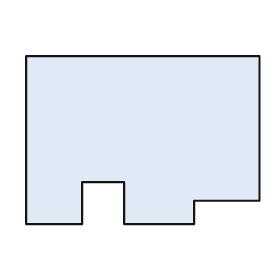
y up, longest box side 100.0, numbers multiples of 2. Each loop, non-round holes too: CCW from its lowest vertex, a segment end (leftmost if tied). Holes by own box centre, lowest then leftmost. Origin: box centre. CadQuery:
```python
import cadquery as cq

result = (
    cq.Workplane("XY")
    .moveTo(-50.0, -36.0)
    .lineTo(-26.0, -36.0)
    .lineTo(-26.0, -18.0)
    .lineTo(-8.0, -18.0)
    .lineTo(-8.0, -36.0)
    .lineTo(22.0, -36.0)
    .lineTo(22.0, -26.0)
    .lineTo(50.0, -26.0)
    .lineTo(50.0, 36.0)
    .lineTo(-50.0, 36.0)
    .close()
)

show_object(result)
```